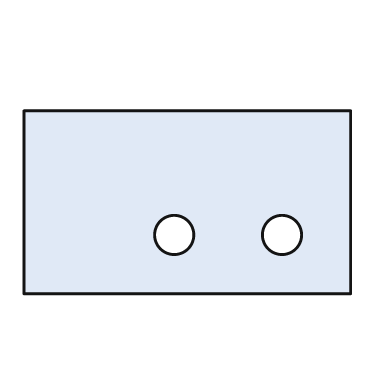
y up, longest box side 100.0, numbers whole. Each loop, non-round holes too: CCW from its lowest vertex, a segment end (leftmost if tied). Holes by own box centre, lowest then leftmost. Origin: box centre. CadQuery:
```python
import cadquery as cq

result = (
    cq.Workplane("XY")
    .moveTo(-50.0, -28.0)
    .lineTo(50.0, -28.0)
    .lineTo(50.0, 28.0)
    .lineTo(-50.0, 28.0)
    .close()
    .moveTo(-4.0, -10.0)
    .circle(6.0)
    .moveTo(29.0, -10.0)
    .circle(6.0)
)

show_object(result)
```